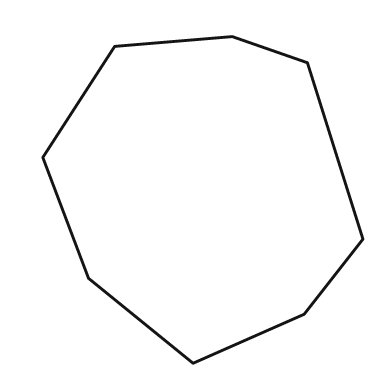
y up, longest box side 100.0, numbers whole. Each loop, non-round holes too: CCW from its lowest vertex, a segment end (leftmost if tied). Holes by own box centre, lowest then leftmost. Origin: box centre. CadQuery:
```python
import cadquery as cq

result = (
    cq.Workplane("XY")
    .moveTo(-3.0, -50.0)
    .lineTo(31.0, -35.0)
    .lineTo(49.0, -12.0)
    .lineTo(32.0, 42.0)
    .lineTo(9.0, 50.0)
    .lineTo(-27.0, 47.0)
    .lineTo(-49.0, 13.0)
    .lineTo(-35.0, -24.0)
    .close()
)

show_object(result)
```